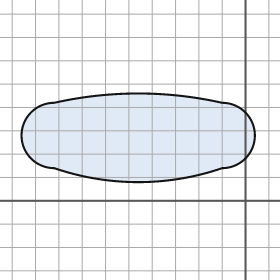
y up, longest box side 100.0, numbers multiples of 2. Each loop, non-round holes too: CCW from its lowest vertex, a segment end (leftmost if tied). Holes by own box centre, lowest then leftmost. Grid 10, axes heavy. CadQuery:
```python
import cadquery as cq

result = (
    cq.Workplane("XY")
    .moveTo(-82.0, 14.0)
    .threePointArc((-46.0, 8.0), (-10.0, 14.0))
    .threePointArc((4.0, 28.0), (-10.0, 42.0))
    .threePointArc((-46.0, 46.0), (-82.0, 42.0))
    .threePointArc((-96.0, 28.0), (-82.0, 14.0))
    .close()
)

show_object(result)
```